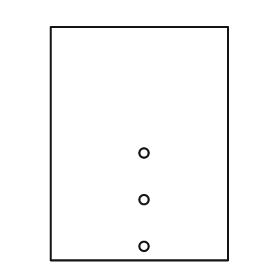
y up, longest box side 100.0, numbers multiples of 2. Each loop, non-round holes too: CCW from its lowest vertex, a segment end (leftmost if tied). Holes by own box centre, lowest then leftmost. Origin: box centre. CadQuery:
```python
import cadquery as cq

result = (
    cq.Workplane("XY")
    .moveTo(-38.0, -50.0)
    .lineTo(38.0, -50.0)
    .lineTo(38.0, 50.0)
    .lineTo(-38.0, 50.0)
    .close()
    .moveTo(2.0, -44.0)
    .circle(2.0)
    .moveTo(2.0, -24.0)
    .circle(2.0)
    .moveTo(2.0, -4.0)
    .circle(2.0)
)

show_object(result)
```